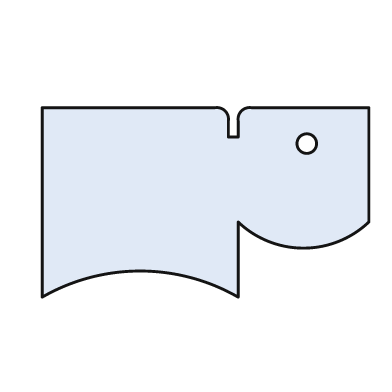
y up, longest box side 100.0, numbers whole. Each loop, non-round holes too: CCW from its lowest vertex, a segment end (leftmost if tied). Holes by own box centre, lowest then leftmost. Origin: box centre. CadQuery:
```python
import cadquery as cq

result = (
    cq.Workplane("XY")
    .moveTo(-50.0, -29.0)
    .threePointArc((-20.0, -21.0), (10.0, -29.0))
    .lineTo(10.0, -6.0)
    .threePointArc((30.0, -14.0), (50.0, -6.0))
    .lineTo(50.0, 29.0)
    .lineTo(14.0, 29.0)
    .threePointArc((11.0, 28.0), (10.0, 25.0))
    .lineTo(10.0, 20.0)
    .lineTo(7.0, 20.0)
    .lineTo(7.0, 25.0)
    .threePointArc((6.0, 28.0), (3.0, 29.0))
    .lineTo(-50.0, 29.0)
    .close()
    .moveTo(31.0, 18.0)
    .circle(3.0)
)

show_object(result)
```